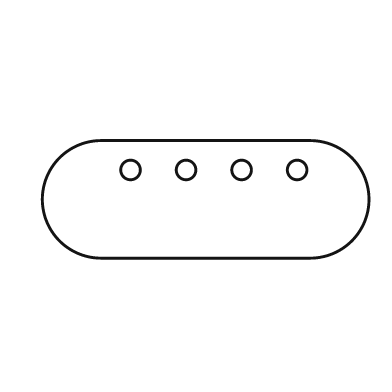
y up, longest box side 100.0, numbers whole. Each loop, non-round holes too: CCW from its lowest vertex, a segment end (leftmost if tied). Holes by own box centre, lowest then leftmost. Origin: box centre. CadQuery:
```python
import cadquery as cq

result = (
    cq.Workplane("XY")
    .moveTo(-32.0, -18.0)
    .lineTo(32.0, -18.0)
    .threePointArc((50.0, 0.0), (32.0, 18.0))
    .lineTo(-32.0, 18.0)
    .threePointArc((-50.0, 0.0), (-32.0, -18.0))
    .close()
    .moveTo(-23.0, 9.0)
    .circle(3.0)
    .moveTo(-6.0, 9.0)
    .circle(3.0)
    .moveTo(11.0, 9.0)
    .circle(3.0)
    .moveTo(28.0, 9.0)
    .circle(3.0)
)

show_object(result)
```